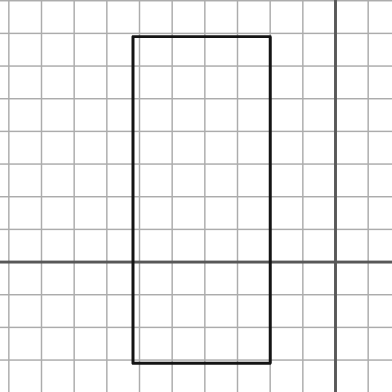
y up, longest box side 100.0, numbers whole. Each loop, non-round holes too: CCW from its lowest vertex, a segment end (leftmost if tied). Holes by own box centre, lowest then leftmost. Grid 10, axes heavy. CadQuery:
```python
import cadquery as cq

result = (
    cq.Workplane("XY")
    .moveTo(-62.0, -31.0)
    .lineTo(-20.0, -31.0)
    .lineTo(-20.0, 69.0)
    .lineTo(-62.0, 69.0)
    .close()
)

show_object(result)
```